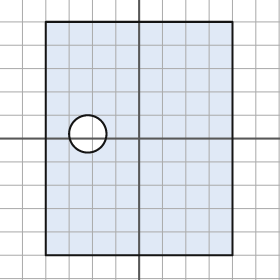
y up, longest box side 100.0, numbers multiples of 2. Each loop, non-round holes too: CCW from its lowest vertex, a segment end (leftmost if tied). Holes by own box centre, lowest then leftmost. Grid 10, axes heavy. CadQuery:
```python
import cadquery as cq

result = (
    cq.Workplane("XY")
    .moveTo(-40.0, -50.0)
    .lineTo(40.0, -50.0)
    .lineTo(40.0, 50.0)
    .lineTo(-40.0, 50.0)
    .close()
    .moveTo(-22.0, 2.0)
    .circle(8.0)
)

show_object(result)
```